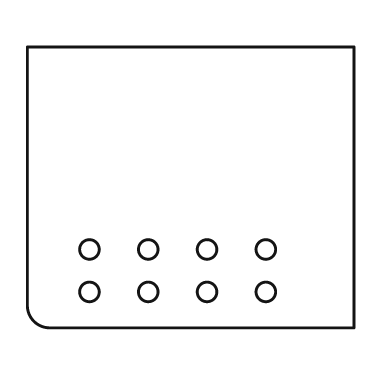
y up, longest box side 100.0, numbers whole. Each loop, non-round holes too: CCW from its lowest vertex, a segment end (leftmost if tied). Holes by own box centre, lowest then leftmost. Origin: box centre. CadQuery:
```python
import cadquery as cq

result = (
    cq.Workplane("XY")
    .moveTo(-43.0, -43.0)
    .lineTo(50.0, -43.0)
    .lineTo(50.0, 43.0)
    .lineTo(-50.0, 43.0)
    .lineTo(-50.0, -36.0)
    .threePointArc((-48.0, -41.0), (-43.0, -43.0))
    .close()
    .moveTo(-31.0, -32.0)
    .circle(3.0)
    .moveTo(-13.0, -32.0)
    .circle(3.0)
    .moveTo(5.0, -32.0)
    .circle(3.0)
    .moveTo(23.0, -32.0)
    .circle(3.0)
    .moveTo(-31.0, -19.0)
    .circle(3.0)
    .moveTo(-13.0, -19.0)
    .circle(3.0)
    .moveTo(5.0, -19.0)
    .circle(3.0)
    .moveTo(23.0, -19.0)
    .circle(3.0)
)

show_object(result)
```